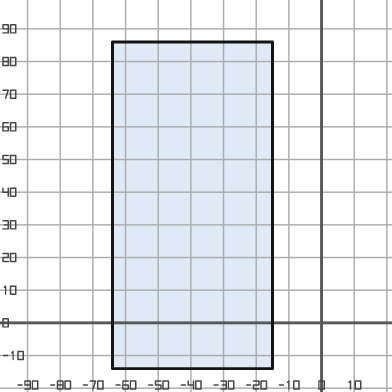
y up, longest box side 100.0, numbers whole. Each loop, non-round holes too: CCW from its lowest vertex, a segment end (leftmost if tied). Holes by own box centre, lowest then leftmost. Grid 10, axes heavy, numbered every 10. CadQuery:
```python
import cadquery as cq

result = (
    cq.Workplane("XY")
    .moveTo(-64.0, -14.0)
    .lineTo(-15.0, -14.0)
    .lineTo(-15.0, 86.0)
    .lineTo(-64.0, 86.0)
    .close()
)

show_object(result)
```